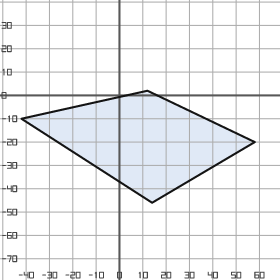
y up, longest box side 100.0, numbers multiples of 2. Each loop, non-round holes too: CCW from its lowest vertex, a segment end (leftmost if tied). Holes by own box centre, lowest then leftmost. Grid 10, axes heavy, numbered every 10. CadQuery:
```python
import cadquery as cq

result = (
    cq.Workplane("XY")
    .moveTo(14.0, -46.0)
    .lineTo(58.0, -20.0)
    .lineTo(12.0, 2.0)
    .lineTo(-42.0, -10.0)
    .close()
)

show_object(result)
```